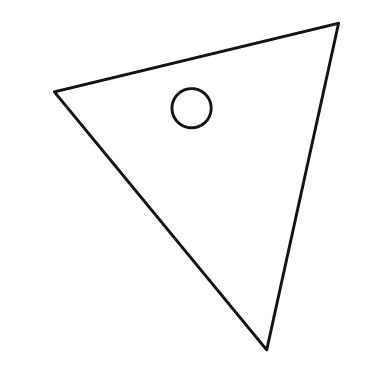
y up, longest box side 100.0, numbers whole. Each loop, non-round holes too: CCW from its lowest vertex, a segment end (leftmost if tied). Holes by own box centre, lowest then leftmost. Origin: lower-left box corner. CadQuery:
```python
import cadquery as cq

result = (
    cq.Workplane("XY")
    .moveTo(65.0, 0.0)
    .lineTo(87.0, 100.0)
    .lineTo(0.0, 79.0)
    .close()
    .moveTo(42.0, 74.0)
    .circle(6.0)
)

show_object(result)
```